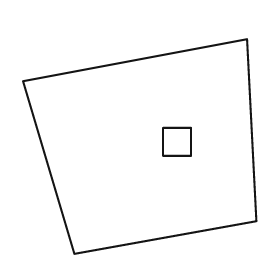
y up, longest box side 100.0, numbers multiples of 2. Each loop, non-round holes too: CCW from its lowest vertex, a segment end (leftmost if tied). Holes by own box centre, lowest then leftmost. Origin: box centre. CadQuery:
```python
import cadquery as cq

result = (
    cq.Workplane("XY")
    .moveTo(-28.0, -46.0)
    .lineTo(50.0, -32.0)
    .lineTo(46.0, 46.0)
    .lineTo(-50.0, 28.0)
    .close()
    .moveTo(10.0, -4.0)
    .lineTo(22.0, -4.0)
    .lineTo(22.0, 8.0)
    .lineTo(10.0, 8.0)
    .close()
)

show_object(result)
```